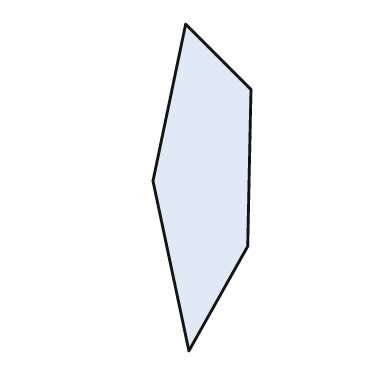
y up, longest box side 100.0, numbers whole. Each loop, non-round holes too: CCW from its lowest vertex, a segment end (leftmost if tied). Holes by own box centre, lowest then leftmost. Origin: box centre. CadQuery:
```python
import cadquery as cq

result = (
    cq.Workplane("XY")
    .moveTo(-4.0, -50.0)
    .lineTo(14.0, -18.0)
    .lineTo(15.0, 30.0)
    .lineTo(-5.0, 50.0)
    .lineTo(-15.0, 2.0)
    .close()
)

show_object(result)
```